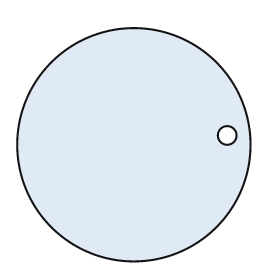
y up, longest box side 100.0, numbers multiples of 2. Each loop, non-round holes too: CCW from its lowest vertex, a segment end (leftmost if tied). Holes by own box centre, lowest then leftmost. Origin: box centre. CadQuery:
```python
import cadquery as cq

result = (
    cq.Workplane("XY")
    .moveTo(0.0, 0.0)
    .circle(50.0)
    .moveTo(40.0, 4.0)
    .circle(4.0)
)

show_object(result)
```